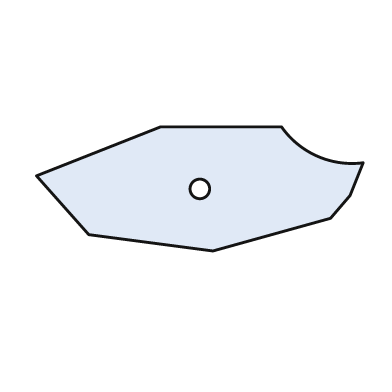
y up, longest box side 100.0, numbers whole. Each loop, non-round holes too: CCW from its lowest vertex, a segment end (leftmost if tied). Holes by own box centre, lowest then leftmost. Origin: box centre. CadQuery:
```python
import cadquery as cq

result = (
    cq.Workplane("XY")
    .moveTo(4.0, -19.0)
    .lineTo(40.0, -9.0)
    .lineTo(46.0, -2.0)
    .lineTo(50.0, 8.0)
    .threePointArc((36.0, 10.0), (25.0, 19.0))
    .lineTo(-12.0, 19.0)
    .lineTo(-50.0, 4.0)
    .lineTo(-34.0, -14.0)
    .close()
    .moveTo(0.0, 0.0)
    .circle(3.0)
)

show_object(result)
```